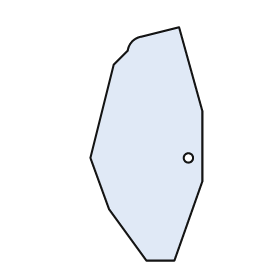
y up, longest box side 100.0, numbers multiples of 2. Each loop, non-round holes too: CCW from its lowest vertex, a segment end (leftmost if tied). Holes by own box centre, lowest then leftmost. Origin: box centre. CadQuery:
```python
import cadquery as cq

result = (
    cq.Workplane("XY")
    .moveTo(0.0, -50.0)
    .lineTo(12.0, -50.0)
    .lineTo(24.0, -16.0)
    .lineTo(24.0, 14.0)
    .lineTo(14.0, 50.0)
    .lineTo(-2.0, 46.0)
    .threePointArc((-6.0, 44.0), (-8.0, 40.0))
    .lineTo(-14.0, 34.0)
    .lineTo(-24.0, -6.0)
    .lineTo(-16.0, -28.0)
    .close()
    .moveTo(18.0, -6.0)
    .circle(2.0)
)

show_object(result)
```